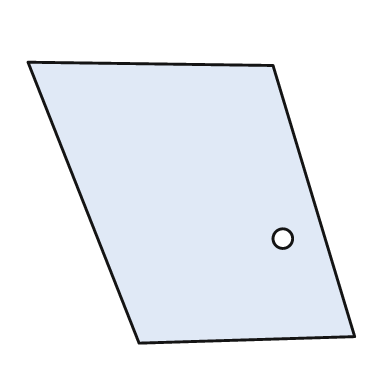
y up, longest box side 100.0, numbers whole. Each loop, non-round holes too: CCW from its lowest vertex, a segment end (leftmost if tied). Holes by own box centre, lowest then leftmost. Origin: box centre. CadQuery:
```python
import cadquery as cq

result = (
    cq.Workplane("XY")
    .moveTo(-16.0, -43.0)
    .lineTo(50.0, -41.0)
    .lineTo(25.0, 42.0)
    .lineTo(-50.0, 43.0)
    .close()
    .moveTo(28.0, -11.0)
    .circle(3.0)
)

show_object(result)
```